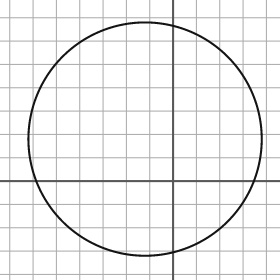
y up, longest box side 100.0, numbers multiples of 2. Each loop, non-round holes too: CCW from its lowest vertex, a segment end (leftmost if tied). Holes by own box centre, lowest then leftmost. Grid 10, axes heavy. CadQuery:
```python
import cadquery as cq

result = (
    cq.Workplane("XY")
    .moveTo(-12.0, 18.0)
    .circle(50.0)
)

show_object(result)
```